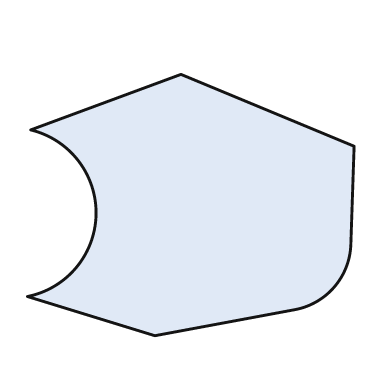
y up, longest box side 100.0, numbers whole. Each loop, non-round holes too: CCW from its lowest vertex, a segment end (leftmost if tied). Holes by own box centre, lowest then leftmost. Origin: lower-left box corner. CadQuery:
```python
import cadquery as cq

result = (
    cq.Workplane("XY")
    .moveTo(39.0, 0.0)
    .lineTo(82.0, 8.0)
    .threePointArc((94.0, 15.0), (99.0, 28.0))
    .lineTo(100.0, 58.0)
    .lineTo(47.0, 80.0)
    .lineTo(1.0, 63.0)
    .threePointArc((21.0, 37.0), (0.0, 12.0))
    .close()
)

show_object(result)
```